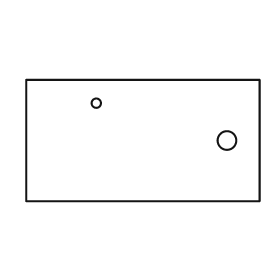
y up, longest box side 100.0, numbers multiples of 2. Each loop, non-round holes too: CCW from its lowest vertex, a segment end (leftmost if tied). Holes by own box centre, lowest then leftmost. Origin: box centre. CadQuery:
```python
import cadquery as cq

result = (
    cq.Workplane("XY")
    .moveTo(-50.0, -26.0)
    .lineTo(50.0, -26.0)
    .lineTo(50.0, 26.0)
    .lineTo(-50.0, 26.0)
    .close()
    .moveTo(36.0, 0.0)
    .circle(4.0)
    .moveTo(-20.0, 16.0)
    .circle(2.0)
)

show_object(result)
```